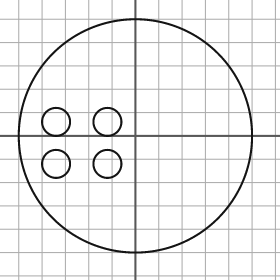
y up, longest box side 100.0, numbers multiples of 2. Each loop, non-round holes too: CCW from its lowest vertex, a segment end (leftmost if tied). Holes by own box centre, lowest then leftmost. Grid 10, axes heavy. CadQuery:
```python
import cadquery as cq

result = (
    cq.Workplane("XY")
    .moveTo(0.0, 0.0)
    .circle(50.0)
    .moveTo(-34.0, -12.0)
    .circle(6.0)
    .moveTo(-12.0, -12.0)
    .circle(6.0)
    .moveTo(-34.0, 6.0)
    .circle(6.0)
    .moveTo(-12.0, 6.0)
    .circle(6.0)
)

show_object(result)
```